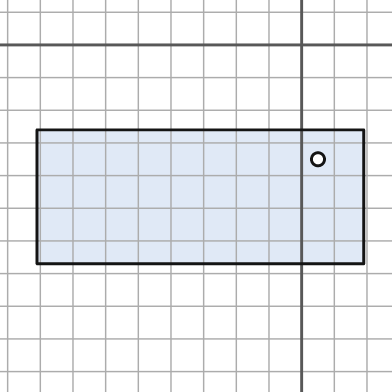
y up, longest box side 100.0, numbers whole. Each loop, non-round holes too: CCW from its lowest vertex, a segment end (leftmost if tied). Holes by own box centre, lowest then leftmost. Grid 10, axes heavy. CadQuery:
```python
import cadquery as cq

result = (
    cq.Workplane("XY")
    .moveTo(-81.0, -67.0)
    .lineTo(19.0, -67.0)
    .lineTo(19.0, -26.0)
    .lineTo(-81.0, -26.0)
    .close()
    .moveTo(5.0, -35.0)
    .circle(2.0)
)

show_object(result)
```